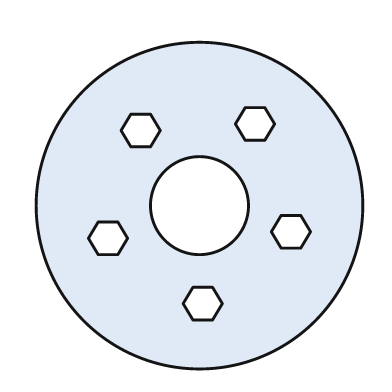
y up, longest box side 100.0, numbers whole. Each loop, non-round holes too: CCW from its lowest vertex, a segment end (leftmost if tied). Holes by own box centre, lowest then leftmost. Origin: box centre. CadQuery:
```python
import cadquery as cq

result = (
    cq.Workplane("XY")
    .moveTo(0.0, 0.0)
    .circle(50.0)
    .moveTo(-2.0, -35.0)
    .lineTo(4.0, -35.0)
    .lineTo(7.0, -30.0)
    .lineTo(4.0, -25.0)
    .lineTo(-2.0, -25.0)
    .lineTo(-5.0, -30.0)
    .close()
    .moveTo(-31.0, -15.0)
    .lineTo(-25.0, -15.0)
    .lineTo(-22.0, -10.0)
    .lineTo(-25.0, -5.0)
    .lineTo(-31.0, -5.0)
    .lineTo(-34.0, -10.0)
    .close()
    .moveTo(25.0, -13.0)
    .lineTo(31.0, -13.0)
    .lineTo(34.0, -8.0)
    .lineTo(31.0, -3.0)
    .lineTo(25.0, -3.0)
    .lineTo(22.0, -8.0)
    .close()
    .moveTo(0.0, 0.0)
    .circle(15.0)
    .moveTo(-21.0, 18.0)
    .lineTo(-15.0, 18.0)
    .lineTo(-12.0, 23.0)
    .lineTo(-15.0, 28.0)
    .lineTo(-21.0, 28.0)
    .lineTo(-24.0, 23.0)
    .close()
    .moveTo(14.0, 20.0)
    .lineTo(20.0, 20.0)
    .lineTo(23.0, 25.0)
    .lineTo(20.0, 30.0)
    .lineTo(14.0, 30.0)
    .lineTo(11.0, 25.0)
    .close()
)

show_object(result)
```